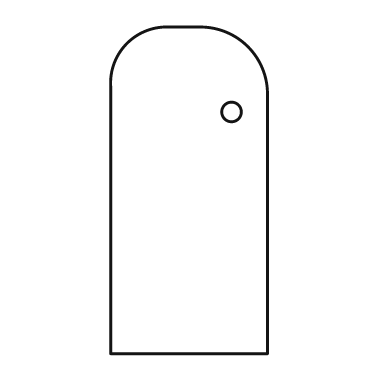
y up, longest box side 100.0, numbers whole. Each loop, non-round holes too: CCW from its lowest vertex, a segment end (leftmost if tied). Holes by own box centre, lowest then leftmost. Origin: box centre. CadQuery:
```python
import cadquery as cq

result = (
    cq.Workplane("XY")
    .moveTo(-24.0, -50.0)
    .lineTo(24.0, -50.0)
    .lineTo(24.0, 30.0)
    .threePointArc((18.0, 44.0), (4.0, 50.0))
    .lineTo(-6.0, 50.0)
    .threePointArc((-19.0, 45.0), (-24.0, 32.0))
    .close()
    .moveTo(13.0, 24.0)
    .circle(3.0)
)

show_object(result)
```